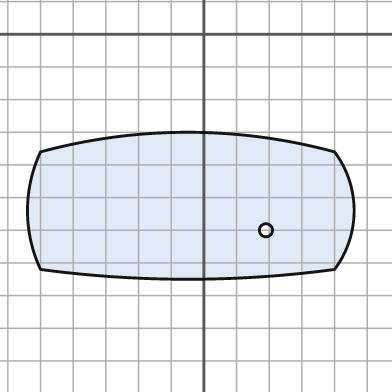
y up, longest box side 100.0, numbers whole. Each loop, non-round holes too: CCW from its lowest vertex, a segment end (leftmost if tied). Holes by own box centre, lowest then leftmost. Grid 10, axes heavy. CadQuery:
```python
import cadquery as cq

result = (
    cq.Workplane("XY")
    .moveTo(-50.0, -72.0)
    .threePointArc((-5.0, -75.0), (40.0, -72.0))
    .threePointArc((46.0, -54.0), (40.0, -36.0))
    .threePointArc((-5.0, -30.0), (-50.0, -36.0))
    .threePointArc((-54.0, -54.0), (-50.0, -72.0))
    .close()
    .moveTo(19.0, -60.0)
    .circle(2.0)
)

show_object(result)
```